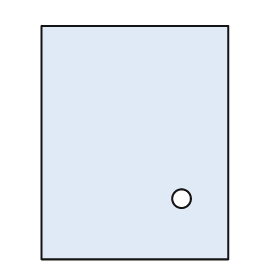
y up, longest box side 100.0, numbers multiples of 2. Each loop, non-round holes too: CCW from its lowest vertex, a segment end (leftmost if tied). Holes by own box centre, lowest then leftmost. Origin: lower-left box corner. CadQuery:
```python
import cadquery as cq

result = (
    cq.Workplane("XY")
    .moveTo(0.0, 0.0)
    .lineTo(80.0, 0.0)
    .lineTo(80.0, 100.0)
    .lineTo(0.0, 100.0)
    .close()
    .moveTo(60.0, 26.0)
    .circle(4.0)
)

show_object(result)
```